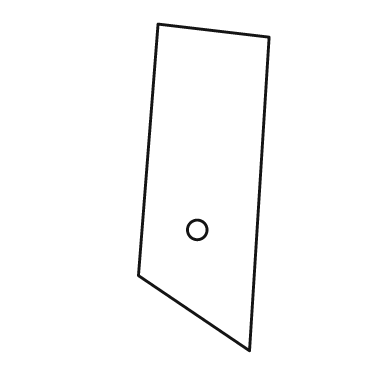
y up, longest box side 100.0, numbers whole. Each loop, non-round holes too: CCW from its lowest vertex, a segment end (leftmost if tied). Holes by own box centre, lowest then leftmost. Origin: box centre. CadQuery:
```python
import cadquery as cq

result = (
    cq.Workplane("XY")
    .moveTo(14.0, -50.0)
    .lineTo(20.0, 46.0)
    .lineTo(-14.0, 50.0)
    .lineTo(-20.0, -27.0)
    .close()
    .moveTo(-2.0, -13.0)
    .circle(3.0)
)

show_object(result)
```